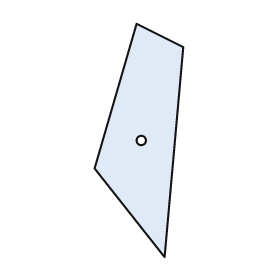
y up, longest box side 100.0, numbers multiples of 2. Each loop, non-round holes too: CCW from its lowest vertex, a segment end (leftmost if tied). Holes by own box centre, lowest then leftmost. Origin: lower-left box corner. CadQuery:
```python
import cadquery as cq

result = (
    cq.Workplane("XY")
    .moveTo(30.0, 0.0)
    .lineTo(38.0, 90.0)
    .lineTo(18.0, 100.0)
    .lineTo(0.0, 38.0)
    .close()
    .moveTo(20.0, 50.0)
    .circle(2.0)
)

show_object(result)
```